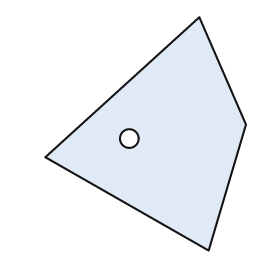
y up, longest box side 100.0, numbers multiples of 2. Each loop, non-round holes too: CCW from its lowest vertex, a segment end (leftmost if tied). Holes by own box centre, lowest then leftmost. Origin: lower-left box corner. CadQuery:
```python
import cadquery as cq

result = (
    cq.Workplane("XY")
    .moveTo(70.0, 0.0)
    .lineTo(86.0, 54.0)
    .lineTo(66.0, 100.0)
    .lineTo(0.0, 40.0)
    .close()
    .moveTo(36.0, 48.0)
    .circle(4.0)
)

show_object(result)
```